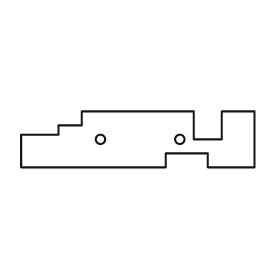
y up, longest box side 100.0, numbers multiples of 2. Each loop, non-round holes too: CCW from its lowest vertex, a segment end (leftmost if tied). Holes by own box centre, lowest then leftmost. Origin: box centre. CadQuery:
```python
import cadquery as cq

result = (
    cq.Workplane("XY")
    .moveTo(-50.0, -12.0)
    .lineTo(12.0, -12.0)
    .lineTo(12.0, -6.0)
    .lineTo(30.0, -6.0)
    .lineTo(30.0, -12.0)
    .lineTo(50.0, -12.0)
    .lineTo(50.0, 12.0)
    .lineTo(36.0, 12.0)
    .lineTo(36.0, 0.0)
    .lineTo(24.0, 0.0)
    .lineTo(24.0, 12.0)
    .lineTo(-24.0, 12.0)
    .lineTo(-24.0, 6.0)
    .lineTo(-34.0, 6.0)
    .lineTo(-34.0, 2.0)
    .lineTo(-50.0, 2.0)
    .close()
    .moveTo(-16.0, 0.0)
    .circle(2.0)
    .moveTo(18.0, 0.0)
    .circle(2.0)
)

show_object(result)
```